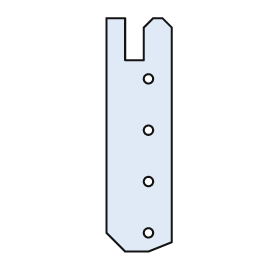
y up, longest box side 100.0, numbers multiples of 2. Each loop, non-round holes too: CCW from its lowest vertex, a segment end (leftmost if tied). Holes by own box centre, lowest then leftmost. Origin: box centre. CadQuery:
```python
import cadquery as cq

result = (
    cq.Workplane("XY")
    .moveTo(-6.0, -50.0)
    .lineTo(4.0, -50.0)
    .lineTo(14.0, -46.0)
    .lineTo(14.0, 46.0)
    .lineTo(10.0, 50.0)
    .lineTo(6.0, 50.0)
    .lineTo(2.0, 46.0)
    .lineTo(2.0, 32.0)
    .lineTo(-6.0, 32.0)
    .lineTo(-6.0, 50.0)
    .lineTo(-14.0, 50.0)
    .lineTo(-14.0, -42.0)
    .close()
    .moveTo(4.0, -42.0)
    .circle(2.0)
    .moveTo(4.0, -20.0)
    .circle(2.0)
    .moveTo(4.0, 2.0)
    .circle(2.0)
    .moveTo(4.0, 24.0)
    .circle(2.0)
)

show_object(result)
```